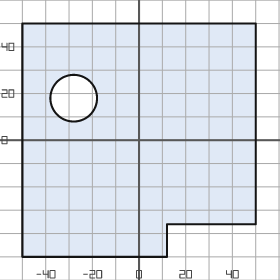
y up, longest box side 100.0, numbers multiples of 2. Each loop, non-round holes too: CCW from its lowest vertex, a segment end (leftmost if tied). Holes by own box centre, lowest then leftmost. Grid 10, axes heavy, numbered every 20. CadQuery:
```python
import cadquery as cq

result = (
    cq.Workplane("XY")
    .moveTo(-50.0, -50.0)
    .lineTo(12.0, -50.0)
    .lineTo(12.0, -36.0)
    .lineTo(50.0, -36.0)
    .lineTo(50.0, 50.0)
    .lineTo(-50.0, 50.0)
    .close()
    .moveTo(-28.0, 18.0)
    .circle(10.0)
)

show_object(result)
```